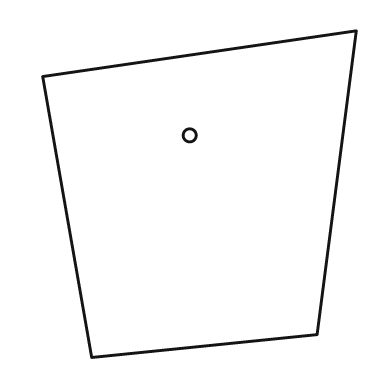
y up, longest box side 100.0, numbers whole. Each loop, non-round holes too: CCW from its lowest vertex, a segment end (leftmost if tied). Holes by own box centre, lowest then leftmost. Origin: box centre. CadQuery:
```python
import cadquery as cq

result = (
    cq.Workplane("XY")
    .moveTo(-33.0, -50.0)
    .lineTo(36.0, -43.0)
    .lineTo(48.0, 50.0)
    .lineTo(-48.0, 36.0)
    .close()
    .moveTo(-3.0, 18.0)
    .circle(2.0)
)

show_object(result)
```